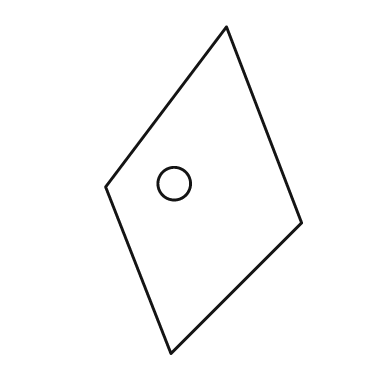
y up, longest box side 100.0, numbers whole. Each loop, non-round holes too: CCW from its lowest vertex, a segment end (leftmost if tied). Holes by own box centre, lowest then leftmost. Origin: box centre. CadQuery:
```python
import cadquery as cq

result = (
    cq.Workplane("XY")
    .moveTo(-10.0, -50.0)
    .lineTo(30.0, -10.0)
    .lineTo(7.0, 50.0)
    .lineTo(-30.0, 1.0)
    .close()
    .moveTo(-9.0, 2.0)
    .circle(5.0)
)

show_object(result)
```